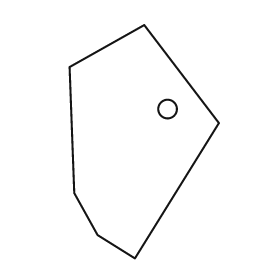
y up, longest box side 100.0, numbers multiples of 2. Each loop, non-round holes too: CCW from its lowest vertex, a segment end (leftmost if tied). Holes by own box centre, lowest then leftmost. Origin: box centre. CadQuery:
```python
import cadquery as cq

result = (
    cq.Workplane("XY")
    .moveTo(-4.0, -50.0)
    .lineTo(32.0, 8.0)
    .lineTo(0.0, 50.0)
    .lineTo(-32.0, 32.0)
    .lineTo(-30.0, -22.0)
    .lineTo(-20.0, -40.0)
    .close()
    .moveTo(10.0, 14.0)
    .circle(4.0)
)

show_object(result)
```